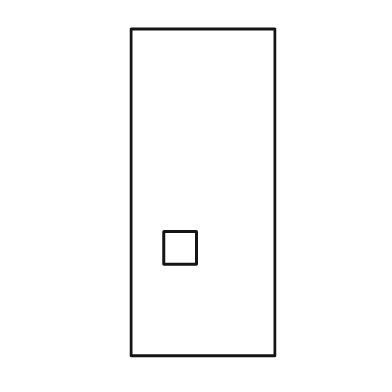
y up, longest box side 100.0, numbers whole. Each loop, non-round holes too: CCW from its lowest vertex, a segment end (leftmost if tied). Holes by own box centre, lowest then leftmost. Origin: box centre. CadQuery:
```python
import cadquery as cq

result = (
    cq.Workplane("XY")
    .moveTo(-22.0, -50.0)
    .lineTo(22.0, -50.0)
    .lineTo(22.0, 50.0)
    .lineTo(-22.0, 50.0)
    .close()
    .moveTo(-12.0, -22.0)
    .lineTo(-2.0, -22.0)
    .lineTo(-2.0, -12.0)
    .lineTo(-12.0, -12.0)
    .close()
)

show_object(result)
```